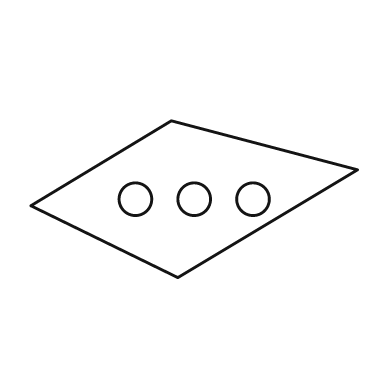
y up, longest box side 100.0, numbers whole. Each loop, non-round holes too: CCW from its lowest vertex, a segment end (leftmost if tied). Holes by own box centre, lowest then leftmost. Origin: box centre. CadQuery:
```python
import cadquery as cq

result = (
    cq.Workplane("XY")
    .moveTo(-5.0, -24.0)
    .lineTo(50.0, 9.0)
    .lineTo(-7.0, 24.0)
    .lineTo(-50.0, -2.0)
    .close()
    .moveTo(-18.0, 0.0)
    .circle(5.0)
    .moveTo(0.0, 0.0)
    .circle(5.0)
    .moveTo(18.0, 0.0)
    .circle(5.0)
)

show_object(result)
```